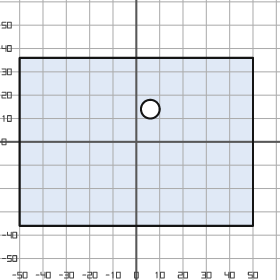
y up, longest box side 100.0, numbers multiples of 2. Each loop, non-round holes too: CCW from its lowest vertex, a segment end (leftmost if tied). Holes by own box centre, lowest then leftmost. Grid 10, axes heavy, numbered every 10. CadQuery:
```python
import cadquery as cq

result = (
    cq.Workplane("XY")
    .moveTo(-50.0, -36.0)
    .lineTo(50.0, -36.0)
    .lineTo(50.0, 36.0)
    .lineTo(-50.0, 36.0)
    .close()
    .moveTo(6.0, 14.0)
    .circle(4.0)
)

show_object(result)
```